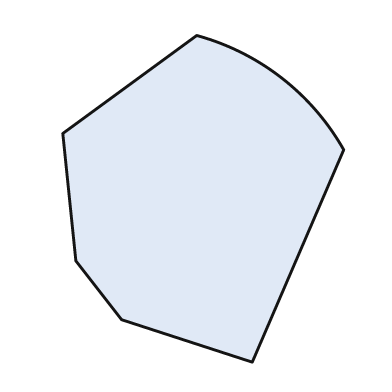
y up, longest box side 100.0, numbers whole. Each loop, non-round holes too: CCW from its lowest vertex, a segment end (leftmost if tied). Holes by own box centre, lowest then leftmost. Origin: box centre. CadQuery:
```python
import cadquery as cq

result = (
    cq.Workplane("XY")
    .moveTo(15.0, -50.0)
    .lineTo(43.0, 15.0)
    .threePointArc((24.0, 37.0), (-2.0, 50.0))
    .lineTo(-43.0, 20.0)
    .lineTo(-39.0, -19.0)
    .lineTo(-25.0, -37.0)
    .close()
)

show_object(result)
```